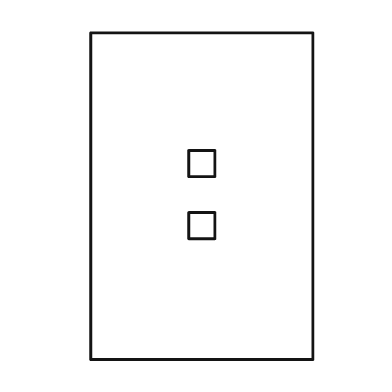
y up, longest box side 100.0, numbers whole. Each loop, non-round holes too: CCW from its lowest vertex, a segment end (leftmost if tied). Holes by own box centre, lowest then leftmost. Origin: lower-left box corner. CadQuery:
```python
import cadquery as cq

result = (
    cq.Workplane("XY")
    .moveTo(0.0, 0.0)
    .lineTo(68.0, 0.0)
    .lineTo(68.0, 100.0)
    .lineTo(0.0, 100.0)
    .close()
    .moveTo(30.0, 37.0)
    .lineTo(38.0, 37.0)
    .lineTo(38.0, 45.0)
    .lineTo(30.0, 45.0)
    .close()
    .moveTo(30.0, 56.0)
    .lineTo(38.0, 56.0)
    .lineTo(38.0, 64.0)
    .lineTo(30.0, 64.0)
    .close()
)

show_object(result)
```